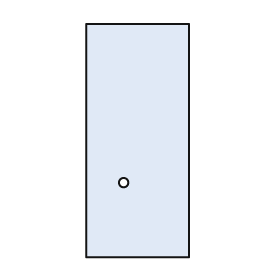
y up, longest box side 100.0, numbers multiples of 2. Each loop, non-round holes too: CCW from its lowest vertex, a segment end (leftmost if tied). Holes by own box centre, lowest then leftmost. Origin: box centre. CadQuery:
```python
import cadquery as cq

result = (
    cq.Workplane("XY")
    .moveTo(-22.0, -50.0)
    .lineTo(22.0, -50.0)
    .lineTo(22.0, 50.0)
    .lineTo(-22.0, 50.0)
    .close()
    .moveTo(-6.0, -18.0)
    .circle(2.0)
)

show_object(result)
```